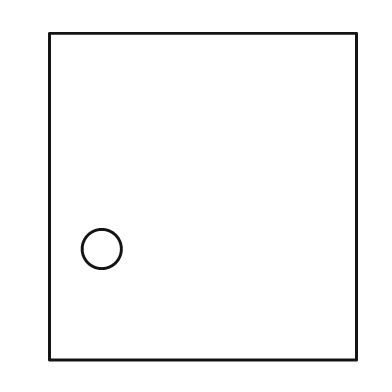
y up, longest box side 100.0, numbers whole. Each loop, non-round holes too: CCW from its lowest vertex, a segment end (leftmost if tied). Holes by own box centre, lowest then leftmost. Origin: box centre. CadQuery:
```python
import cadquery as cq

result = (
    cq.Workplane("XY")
    .moveTo(-47.0, -50.0)
    .lineTo(47.0, -50.0)
    .lineTo(47.0, 50.0)
    .lineTo(-47.0, 50.0)
    .close()
    .moveTo(-31.0, -16.0)
    .circle(6.0)
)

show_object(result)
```